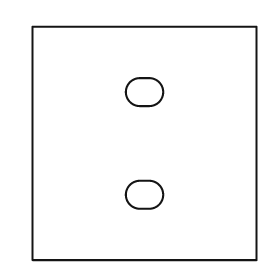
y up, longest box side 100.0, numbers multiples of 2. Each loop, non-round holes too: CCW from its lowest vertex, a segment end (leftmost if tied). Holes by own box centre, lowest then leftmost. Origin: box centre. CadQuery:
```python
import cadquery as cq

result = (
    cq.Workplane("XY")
    .moveTo(-48.0, -50.0)
    .lineTo(48.0, -50.0)
    .lineTo(48.0, 50.0)
    .lineTo(-48.0, 50.0)
    .close()
    .moveTo(-2.0, -28.0)
    .lineTo(2.0, -28.0)
    .threePointArc((8.0, -22.0), (2.0, -16.0))
    .lineTo(-2.0, -16.0)
    .threePointArc((-8.0, -22.0), (-2.0, -28.0))
    .close()
    .moveTo(-2.0, 16.0)
    .lineTo(2.0, 16.0)
    .threePointArc((8.0, 22.0), (2.0, 28.0))
    .lineTo(-2.0, 28.0)
    .threePointArc((-8.0, 22.0), (-2.0, 16.0))
    .close()
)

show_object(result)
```